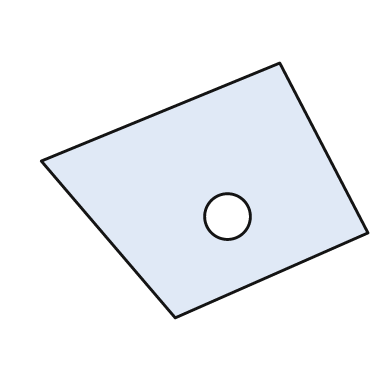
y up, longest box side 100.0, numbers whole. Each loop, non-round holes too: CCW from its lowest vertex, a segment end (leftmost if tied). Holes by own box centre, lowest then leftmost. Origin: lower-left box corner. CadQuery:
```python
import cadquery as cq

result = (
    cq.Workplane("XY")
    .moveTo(41.0, 0.0)
    .lineTo(100.0, 26.0)
    .lineTo(73.0, 78.0)
    .lineTo(0.0, 48.0)
    .close()
    .moveTo(57.0, 31.0)
    .circle(7.0)
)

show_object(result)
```